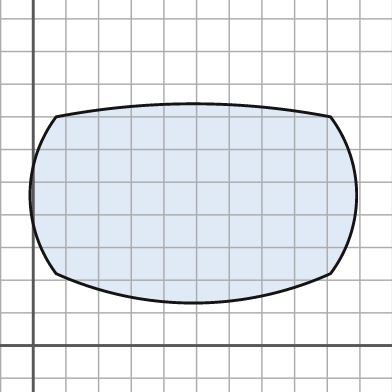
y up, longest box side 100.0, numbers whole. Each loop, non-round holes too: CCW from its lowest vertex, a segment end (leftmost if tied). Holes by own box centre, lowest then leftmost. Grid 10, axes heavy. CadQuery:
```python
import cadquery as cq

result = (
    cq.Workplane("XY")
    .moveTo(7.0, 22.0)
    .threePointArc((49.0, 13.0), (91.0, 22.0))
    .threePointArc((99.0, 46.0), (91.0, 70.0))
    .threePointArc((49.0, 74.0), (7.0, 70.0))
    .threePointArc((-1.0, 46.0), (7.0, 22.0))
    .close()
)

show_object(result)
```